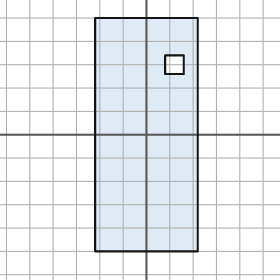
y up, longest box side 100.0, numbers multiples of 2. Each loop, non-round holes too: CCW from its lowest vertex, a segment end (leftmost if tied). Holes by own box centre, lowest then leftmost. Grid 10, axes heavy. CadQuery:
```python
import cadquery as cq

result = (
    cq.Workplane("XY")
    .moveTo(-22.0, -50.0)
    .lineTo(22.0, -50.0)
    .lineTo(22.0, 50.0)
    .lineTo(-22.0, 50.0)
    .close()
    .moveTo(8.0, 26.0)
    .lineTo(16.0, 26.0)
    .lineTo(16.0, 34.0)
    .lineTo(8.0, 34.0)
    .close()
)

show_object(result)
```